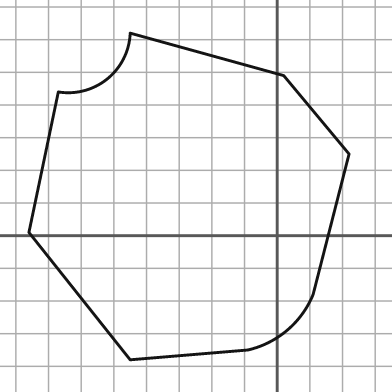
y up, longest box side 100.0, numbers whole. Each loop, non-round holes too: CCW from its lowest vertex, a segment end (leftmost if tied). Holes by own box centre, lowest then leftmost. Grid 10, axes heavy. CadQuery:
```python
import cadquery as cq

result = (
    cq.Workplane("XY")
    .moveTo(-45.0, -38.0)
    .lineTo(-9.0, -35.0)
    .threePointArc((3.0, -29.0), (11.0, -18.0))
    .lineTo(22.0, 25.0)
    .lineTo(2.0, 49.0)
    .lineTo(-45.0, 62.0)
    .threePointArc((-52.0, 48.0), (-67.0, 44.0))
    .lineTo(-76.0, 1.0)
    .close()
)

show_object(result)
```